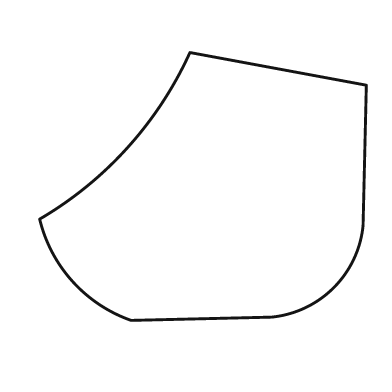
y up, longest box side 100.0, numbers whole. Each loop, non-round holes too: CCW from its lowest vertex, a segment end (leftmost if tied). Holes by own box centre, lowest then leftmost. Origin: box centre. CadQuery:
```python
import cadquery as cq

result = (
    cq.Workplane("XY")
    .moveTo(-22.0, -41.0)
    .lineTo(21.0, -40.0)
    .threePointArc((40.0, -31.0), (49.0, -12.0))
    .lineTo(50.0, 31.0)
    .lineTo(-4.0, 41.0)
    .threePointArc((-23.0, 12.0), (-50.0, -10.0))
    .threePointArc((-40.0, -29.0), (-22.0, -41.0))
    .close()
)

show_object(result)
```